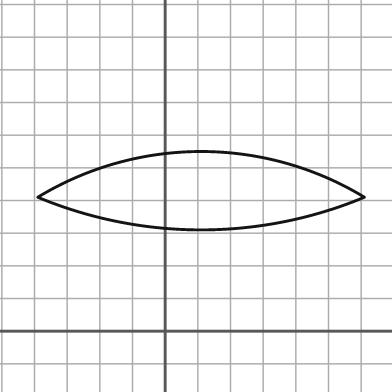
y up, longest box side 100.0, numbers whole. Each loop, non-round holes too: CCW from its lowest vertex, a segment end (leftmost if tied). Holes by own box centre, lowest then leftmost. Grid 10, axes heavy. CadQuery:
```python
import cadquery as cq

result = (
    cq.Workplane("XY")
    .moveTo(-39.0, 41.0)
    .threePointArc((11.0, 31.0), (61.0, 41.0))
    .threePointArc((11.0, 55.0), (-39.0, 41.0))
    .close()
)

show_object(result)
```